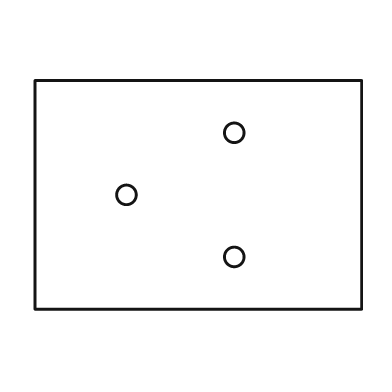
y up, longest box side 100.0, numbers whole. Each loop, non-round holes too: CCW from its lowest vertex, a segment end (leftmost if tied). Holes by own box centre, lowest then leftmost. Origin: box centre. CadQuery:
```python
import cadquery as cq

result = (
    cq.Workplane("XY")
    .moveTo(-50.0, -35.0)
    .lineTo(50.0, -35.0)
    .lineTo(50.0, 35.0)
    .lineTo(-50.0, 35.0)
    .close()
    .moveTo(11.0, -19.0)
    .circle(3.0)
    .moveTo(-22.0, 0.0)
    .circle(3.0)
    .moveTo(11.0, 19.0)
    .circle(3.0)
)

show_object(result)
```